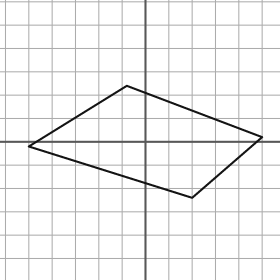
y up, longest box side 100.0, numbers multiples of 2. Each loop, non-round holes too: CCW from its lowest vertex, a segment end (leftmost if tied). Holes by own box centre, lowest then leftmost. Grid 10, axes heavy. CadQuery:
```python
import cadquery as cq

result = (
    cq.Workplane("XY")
    .moveTo(20.0, -24.0)
    .lineTo(50.0, 2.0)
    .lineTo(-8.0, 24.0)
    .lineTo(-50.0, -2.0)
    .close()
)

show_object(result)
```